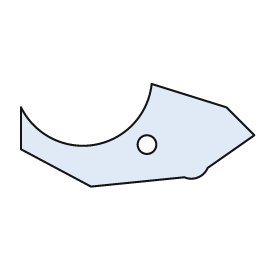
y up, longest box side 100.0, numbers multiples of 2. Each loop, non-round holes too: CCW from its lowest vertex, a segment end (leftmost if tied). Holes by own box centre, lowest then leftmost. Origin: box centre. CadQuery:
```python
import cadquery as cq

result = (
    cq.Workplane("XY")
    .moveTo(-20.0, -22.0)
    .lineTo(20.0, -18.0)
    .threePointArc((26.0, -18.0), (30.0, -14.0))
    .lineTo(50.0, 0.0)
    .lineTo(38.0, 12.0)
    .lineTo(6.0, 22.0)
    .threePointArc((-18.0, -4.0), (-50.0, 12.0))
    .lineTo(-50.0, -6.0)
    .close()
    .moveTo(4.0, -4.0)
    .circle(4.0)
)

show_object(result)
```